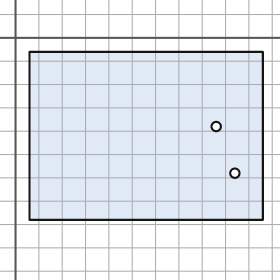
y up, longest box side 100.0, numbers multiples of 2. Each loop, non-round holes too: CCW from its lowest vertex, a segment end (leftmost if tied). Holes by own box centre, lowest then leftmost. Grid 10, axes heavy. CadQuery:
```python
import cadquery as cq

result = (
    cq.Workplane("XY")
    .moveTo(6.0, -78.0)
    .lineTo(106.0, -78.0)
    .lineTo(106.0, -6.0)
    .lineTo(6.0, -6.0)
    .close()
    .moveTo(94.0, -58.0)
    .circle(2.0)
    .moveTo(86.0, -38.0)
    .circle(2.0)
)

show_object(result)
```